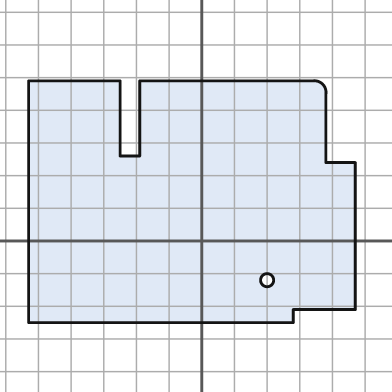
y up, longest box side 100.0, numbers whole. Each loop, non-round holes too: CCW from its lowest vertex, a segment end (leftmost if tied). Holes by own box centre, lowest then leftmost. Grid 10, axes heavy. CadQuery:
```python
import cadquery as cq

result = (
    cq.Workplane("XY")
    .moveTo(-53.0, -25.0)
    .lineTo(28.0, -25.0)
    .lineTo(28.0, -21.0)
    .lineTo(47.0, -21.0)
    .lineTo(47.0, 24.0)
    .lineTo(38.0, 24.0)
    .lineTo(38.0, 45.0)
    .threePointArc((37.0, 48.0), (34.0, 49.0))
    .lineTo(-19.0, 49.0)
    .lineTo(-19.0, 26.0)
    .lineTo(-25.0, 26.0)
    .lineTo(-25.0, 49.0)
    .lineTo(-53.0, 49.0)
    .close()
    .moveTo(20.0, -12.0)
    .circle(2.0)
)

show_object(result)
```